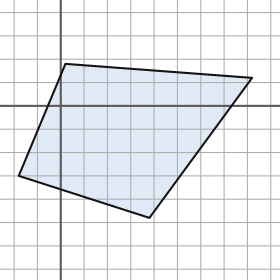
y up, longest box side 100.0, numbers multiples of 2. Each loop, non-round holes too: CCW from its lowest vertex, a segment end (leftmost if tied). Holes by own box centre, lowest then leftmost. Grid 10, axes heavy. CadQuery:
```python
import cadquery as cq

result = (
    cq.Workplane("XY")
    .moveTo(38.0, -48.0)
    .lineTo(82.0, 12.0)
    .lineTo(2.0, 18.0)
    .lineTo(-18.0, -30.0)
    .close()
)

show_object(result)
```